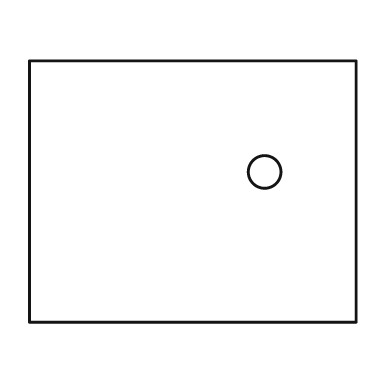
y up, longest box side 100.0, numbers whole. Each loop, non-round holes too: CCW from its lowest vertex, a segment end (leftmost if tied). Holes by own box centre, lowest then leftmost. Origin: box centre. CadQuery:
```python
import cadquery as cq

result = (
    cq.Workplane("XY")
    .moveTo(-50.0, -40.0)
    .lineTo(50.0, -40.0)
    .lineTo(50.0, 40.0)
    .lineTo(-50.0, 40.0)
    .close()
    .moveTo(22.0, 6.0)
    .circle(5.0)
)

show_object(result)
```